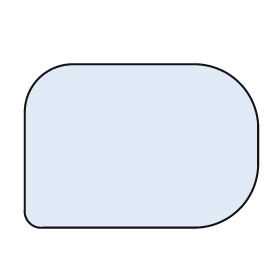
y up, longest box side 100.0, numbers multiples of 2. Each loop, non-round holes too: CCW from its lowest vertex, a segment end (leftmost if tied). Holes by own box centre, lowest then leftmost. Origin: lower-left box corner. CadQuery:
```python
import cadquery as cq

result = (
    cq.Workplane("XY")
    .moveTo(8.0, 0.0)
    .lineTo(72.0, 0.0)
    .threePointArc((92.0, 8.0), (100.0, 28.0))
    .lineTo(100.0, 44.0)
    .threePointArc((92.0, 62.0), (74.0, 70.0))
    .lineTo(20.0, 70.0)
    .threePointArc((6.0, 64.0), (0.0, 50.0))
    .lineTo(0.0, 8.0)
    .threePointArc((2.0, 2.0), (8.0, 0.0))
    .close()
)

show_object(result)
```